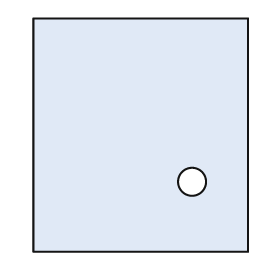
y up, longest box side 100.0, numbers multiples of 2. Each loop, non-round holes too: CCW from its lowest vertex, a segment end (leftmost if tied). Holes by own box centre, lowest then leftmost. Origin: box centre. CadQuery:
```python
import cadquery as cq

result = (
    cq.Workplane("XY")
    .moveTo(-46.0, -50.0)
    .lineTo(46.0, -50.0)
    .lineTo(46.0, 50.0)
    .lineTo(-46.0, 50.0)
    .close()
    .moveTo(22.0, -20.0)
    .circle(6.0)
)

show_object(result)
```